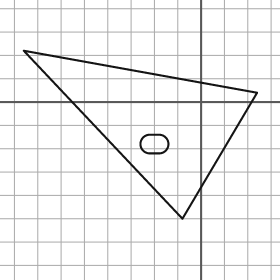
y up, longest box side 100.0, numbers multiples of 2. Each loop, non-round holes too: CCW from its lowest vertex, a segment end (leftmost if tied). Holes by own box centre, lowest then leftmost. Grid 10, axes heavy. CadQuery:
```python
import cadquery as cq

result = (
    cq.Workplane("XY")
    .moveTo(-8.0, -50.0)
    .lineTo(24.0, 4.0)
    .lineTo(-76.0, 22.0)
    .close()
    .moveTo(-22.0, -22.0)
    .lineTo(-18.0, -22.0)
    .threePointArc((-14.0, -18.0), (-18.0, -14.0))
    .lineTo(-22.0, -14.0)
    .threePointArc((-26.0, -18.0), (-22.0, -22.0))
    .close()
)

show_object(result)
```